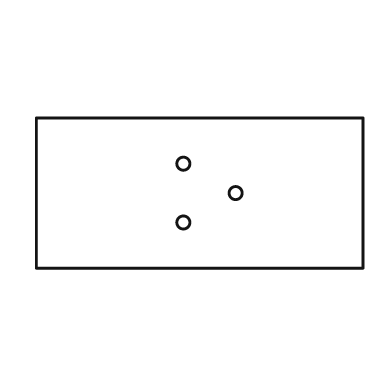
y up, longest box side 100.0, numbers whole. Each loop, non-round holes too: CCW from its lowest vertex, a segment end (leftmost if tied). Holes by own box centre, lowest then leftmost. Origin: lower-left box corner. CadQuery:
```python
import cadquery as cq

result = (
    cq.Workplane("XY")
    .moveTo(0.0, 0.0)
    .lineTo(100.0, 0.0)
    .lineTo(100.0, 46.0)
    .lineTo(0.0, 46.0)
    .close()
    .moveTo(45.0, 14.0)
    .circle(2.0)
    .moveTo(61.0, 23.0)
    .circle(2.0)
    .moveTo(45.0, 32.0)
    .circle(2.0)
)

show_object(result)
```